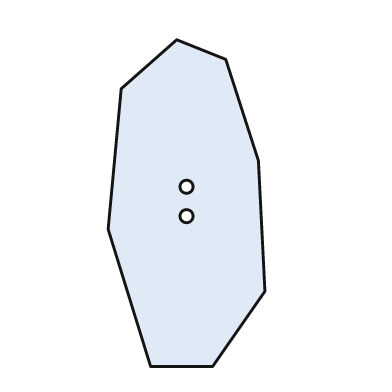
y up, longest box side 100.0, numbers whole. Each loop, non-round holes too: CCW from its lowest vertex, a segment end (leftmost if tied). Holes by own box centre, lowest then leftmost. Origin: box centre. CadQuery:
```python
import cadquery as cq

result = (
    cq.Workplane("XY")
    .moveTo(-11.0, -50.0)
    .lineTo(8.0, -50.0)
    .lineTo(24.0, -27.0)
    .lineTo(22.0, 13.0)
    .lineTo(12.0, 44.0)
    .lineTo(-3.0, 50.0)
    .lineTo(-20.0, 35.0)
    .lineTo(-24.0, -8.0)
    .close()
    .moveTo(0.0, -4.0)
    .circle(2.0)
    .moveTo(0.0, 5.0)
    .circle(2.0)
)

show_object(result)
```